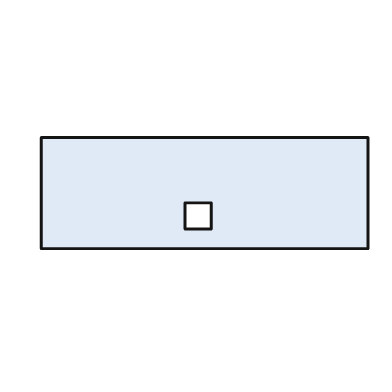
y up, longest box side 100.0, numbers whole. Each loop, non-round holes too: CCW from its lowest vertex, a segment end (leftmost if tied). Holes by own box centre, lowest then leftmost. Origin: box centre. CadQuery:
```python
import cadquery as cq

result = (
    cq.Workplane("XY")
    .moveTo(-50.0, -17.0)
    .lineTo(50.0, -17.0)
    .lineTo(50.0, 17.0)
    .lineTo(-50.0, 17.0)
    .close()
    .moveTo(-6.0, -11.0)
    .lineTo(2.0, -11.0)
    .lineTo(2.0, -3.0)
    .lineTo(-6.0, -3.0)
    .close()
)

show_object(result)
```